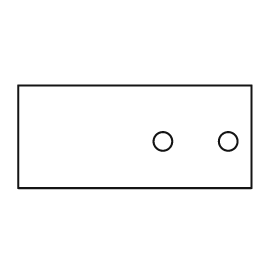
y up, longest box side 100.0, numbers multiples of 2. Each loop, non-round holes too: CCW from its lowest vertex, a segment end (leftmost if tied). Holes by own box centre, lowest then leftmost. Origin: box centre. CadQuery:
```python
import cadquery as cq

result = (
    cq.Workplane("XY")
    .moveTo(-50.0, -22.0)
    .lineTo(50.0, -22.0)
    .lineTo(50.0, 22.0)
    .lineTo(-50.0, 22.0)
    .close()
    .moveTo(12.0, -2.0)
    .circle(4.0)
    .moveTo(40.0, -2.0)
    .circle(4.0)
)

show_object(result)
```